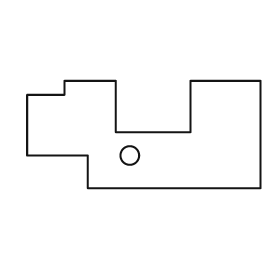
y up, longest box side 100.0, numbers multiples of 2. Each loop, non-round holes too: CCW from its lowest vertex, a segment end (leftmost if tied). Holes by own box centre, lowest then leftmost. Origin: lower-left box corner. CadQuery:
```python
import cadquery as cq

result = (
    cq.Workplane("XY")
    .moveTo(26.0, 0.0)
    .lineTo(100.0, 0.0)
    .lineTo(100.0, 46.0)
    .lineTo(70.0, 46.0)
    .lineTo(70.0, 24.0)
    .lineTo(38.0, 24.0)
    .lineTo(38.0, 46.0)
    .lineTo(16.0, 46.0)
    .lineTo(16.0, 40.0)
    .lineTo(0.0, 40.0)
    .lineTo(0.0, 14.0)
    .lineTo(26.0, 14.0)
    .close()
    .moveTo(44.0, 14.0)
    .circle(4.0)
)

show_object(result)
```